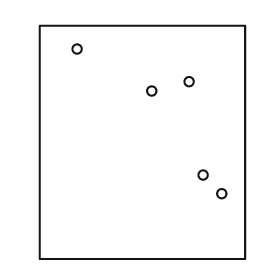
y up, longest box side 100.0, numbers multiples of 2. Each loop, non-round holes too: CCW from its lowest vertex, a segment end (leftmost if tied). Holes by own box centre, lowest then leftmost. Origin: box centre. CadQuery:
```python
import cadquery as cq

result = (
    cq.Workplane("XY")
    .moveTo(-44.0, -50.0)
    .lineTo(44.0, -50.0)
    .lineTo(44.0, 50.0)
    .lineTo(-44.0, 50.0)
    .close()
    .moveTo(34.0, -22.0)
    .circle(2.0)
    .moveTo(26.0, -14.0)
    .circle(2.0)
    .moveTo(4.0, 22.0)
    .circle(2.0)
    .moveTo(20.0, 26.0)
    .circle(2.0)
    .moveTo(-28.0, 40.0)
    .circle(2.0)
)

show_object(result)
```